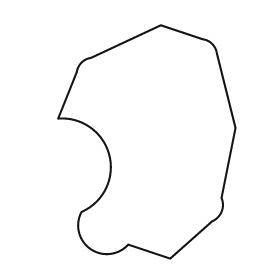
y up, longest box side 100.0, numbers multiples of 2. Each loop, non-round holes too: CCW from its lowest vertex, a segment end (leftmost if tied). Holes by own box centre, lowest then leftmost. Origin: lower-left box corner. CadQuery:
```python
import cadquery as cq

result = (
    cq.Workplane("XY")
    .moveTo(48.0, 0.0)
    .lineTo(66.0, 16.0)
    .threePointArc((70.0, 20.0), (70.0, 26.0))
    .lineTo(76.0, 56.0)
    .lineTo(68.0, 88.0)
    .threePointArc((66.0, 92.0), (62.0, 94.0))
    .lineTo(44.0, 100.0)
    .lineTo(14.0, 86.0)
    .threePointArc((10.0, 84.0), (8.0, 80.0))
    .lineTo(0.0, 60.0)
    .threePointArc((22.0, 44.0), (10.0, 20.0))
    .threePointArc((14.0, 4.0), (30.0, 6.0))
    .close()
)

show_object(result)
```